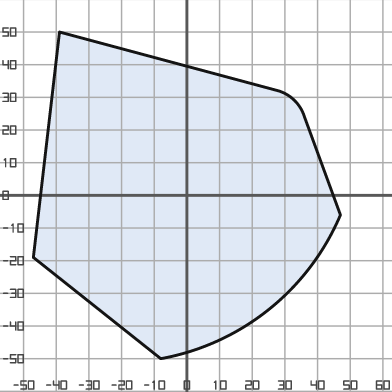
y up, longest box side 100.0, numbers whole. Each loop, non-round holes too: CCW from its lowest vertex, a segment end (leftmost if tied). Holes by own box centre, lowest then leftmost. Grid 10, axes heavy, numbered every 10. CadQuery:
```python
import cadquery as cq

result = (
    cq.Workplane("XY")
    .moveTo(-8.0, -50.0)
    .threePointArc((25.0, -35.0), (47.0, -6.0))
    .lineTo(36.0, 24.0)
    .threePointArc((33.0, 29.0), (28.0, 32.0))
    .lineTo(-39.0, 50.0)
    .lineTo(-47.0, -19.0)
    .close()
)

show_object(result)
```